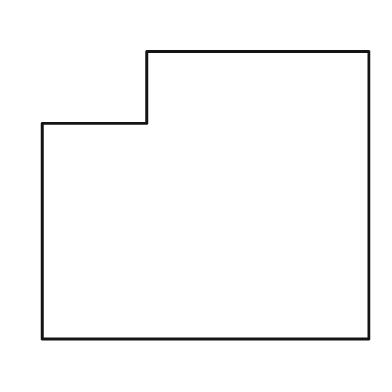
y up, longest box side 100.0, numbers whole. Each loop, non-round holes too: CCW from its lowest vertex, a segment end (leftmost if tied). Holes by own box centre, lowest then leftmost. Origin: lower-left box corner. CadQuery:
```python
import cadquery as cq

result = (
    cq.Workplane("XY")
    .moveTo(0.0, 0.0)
    .lineTo(100.0, 0.0)
    .lineTo(100.0, 88.0)
    .lineTo(32.0, 88.0)
    .lineTo(32.0, 66.0)
    .lineTo(0.0, 66.0)
    .close()
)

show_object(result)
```